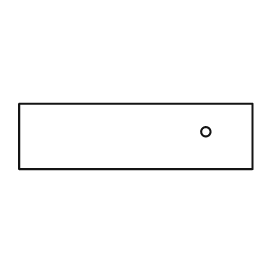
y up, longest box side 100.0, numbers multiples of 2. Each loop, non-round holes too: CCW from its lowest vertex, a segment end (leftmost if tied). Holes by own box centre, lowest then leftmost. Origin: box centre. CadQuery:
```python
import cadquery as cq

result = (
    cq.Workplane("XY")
    .moveTo(-50.0, -14.0)
    .lineTo(50.0, -14.0)
    .lineTo(50.0, 14.0)
    .lineTo(-50.0, 14.0)
    .close()
    .moveTo(30.0, 2.0)
    .circle(2.0)
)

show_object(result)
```